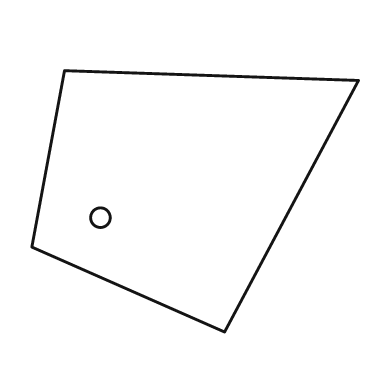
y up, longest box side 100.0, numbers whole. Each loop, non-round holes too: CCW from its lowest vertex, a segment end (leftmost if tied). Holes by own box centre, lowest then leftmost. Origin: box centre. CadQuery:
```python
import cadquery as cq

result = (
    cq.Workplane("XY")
    .moveTo(9.0, -40.0)
    .lineTo(50.0, 37.0)
    .lineTo(-40.0, 40.0)
    .lineTo(-50.0, -14.0)
    .close()
    .moveTo(-29.0, -5.0)
    .circle(3.0)
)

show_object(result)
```